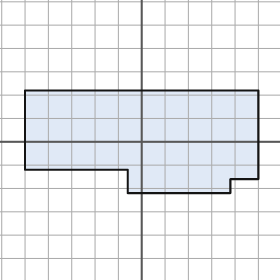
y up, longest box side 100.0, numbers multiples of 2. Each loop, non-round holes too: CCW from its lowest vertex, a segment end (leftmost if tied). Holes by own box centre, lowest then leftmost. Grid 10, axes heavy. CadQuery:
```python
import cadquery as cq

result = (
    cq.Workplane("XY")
    .moveTo(-6.0, -22.0)
    .lineTo(38.0, -22.0)
    .lineTo(38.0, -16.0)
    .lineTo(50.0, -16.0)
    .lineTo(50.0, 22.0)
    .lineTo(-50.0, 22.0)
    .lineTo(-50.0, -12.0)
    .lineTo(-6.0, -12.0)
    .close()
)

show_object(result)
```